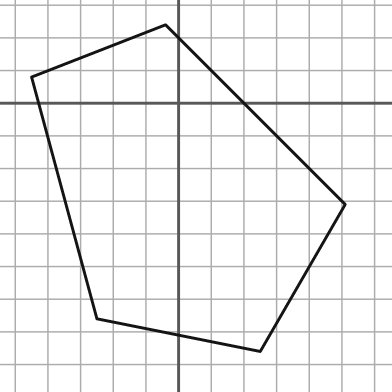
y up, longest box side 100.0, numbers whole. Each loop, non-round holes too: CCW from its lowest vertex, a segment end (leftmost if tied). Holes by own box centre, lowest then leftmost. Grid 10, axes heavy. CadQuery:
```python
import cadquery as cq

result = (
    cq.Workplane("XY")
    .moveTo(25.0, -76.0)
    .lineTo(51.0, -31.0)
    .lineTo(-4.0, 24.0)
    .lineTo(-45.0, 8.0)
    .lineTo(-25.0, -66.0)
    .close()
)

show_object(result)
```